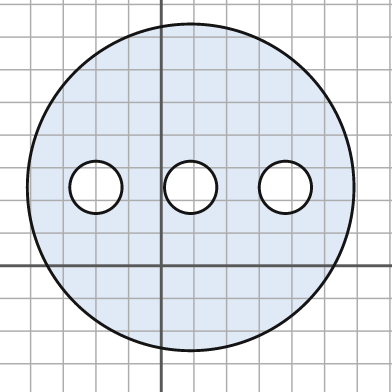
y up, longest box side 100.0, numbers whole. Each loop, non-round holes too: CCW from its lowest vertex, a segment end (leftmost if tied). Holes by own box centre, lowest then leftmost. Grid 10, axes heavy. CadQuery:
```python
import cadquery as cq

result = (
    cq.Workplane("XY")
    .moveTo(9.0, 24.0)
    .circle(50.0)
    .moveTo(-20.0, 24.0)
    .circle(8.0)
    .moveTo(9.0, 24.0)
    .circle(8.0)
    .moveTo(38.0, 24.0)
    .circle(8.0)
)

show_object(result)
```